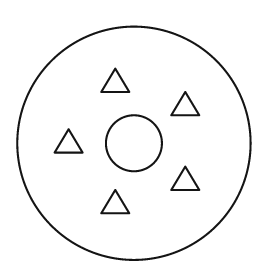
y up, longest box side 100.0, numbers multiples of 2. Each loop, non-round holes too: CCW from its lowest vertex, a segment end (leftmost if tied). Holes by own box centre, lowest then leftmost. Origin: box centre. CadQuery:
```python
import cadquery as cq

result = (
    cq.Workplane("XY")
    .moveTo(0.0, 0.0)
    .circle(50.0)
    .moveTo(-14.0, -30.0)
    .lineTo(-2.0, -30.0)
    .lineTo(-8.0, -20.0)
    .close()
    .moveTo(16.0, -20.0)
    .lineTo(28.0, -20.0)
    .lineTo(22.0, -10.0)
    .close()
    .moveTo(0.0, 0.0)
    .circle(12.0)
    .moveTo(-34.0, -4.0)
    .lineTo(-22.0, -4.0)
    .lineTo(-28.0, 6.0)
    .close()
    .moveTo(16.0, 12.0)
    .lineTo(28.0, 12.0)
    .lineTo(22.0, 22.0)
    .close()
    .moveTo(-14.0, 22.0)
    .lineTo(-2.0, 22.0)
    .lineTo(-8.0, 32.0)
    .close()
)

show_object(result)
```